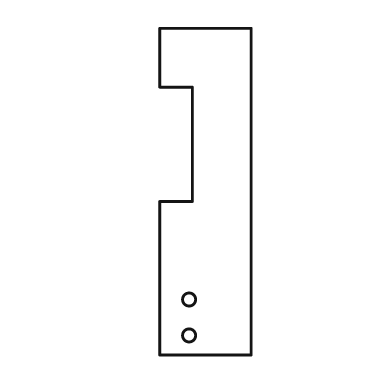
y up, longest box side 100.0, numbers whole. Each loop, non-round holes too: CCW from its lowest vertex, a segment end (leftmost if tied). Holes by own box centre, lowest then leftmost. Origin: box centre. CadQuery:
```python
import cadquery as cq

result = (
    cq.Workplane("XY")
    .moveTo(-14.0, -50.0)
    .lineTo(14.0, -50.0)
    .lineTo(14.0, 50.0)
    .lineTo(-14.0, 50.0)
    .lineTo(-14.0, 32.0)
    .lineTo(-4.0, 32.0)
    .lineTo(-4.0, -3.0)
    .lineTo(-14.0, -3.0)
    .close()
    .moveTo(-5.0, -44.0)
    .circle(2.0)
    .moveTo(-5.0, -33.0)
    .circle(2.0)
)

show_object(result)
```